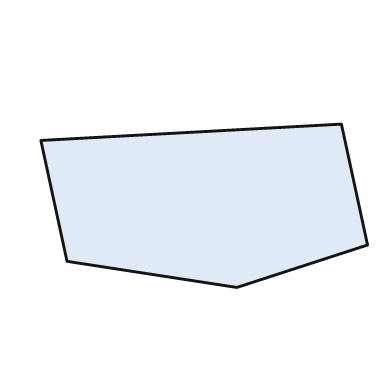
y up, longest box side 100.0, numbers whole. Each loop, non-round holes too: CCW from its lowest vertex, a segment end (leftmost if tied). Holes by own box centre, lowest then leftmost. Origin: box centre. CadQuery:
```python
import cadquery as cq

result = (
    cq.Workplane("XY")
    .moveTo(10.0, -25.0)
    .lineTo(50.0, -12.0)
    .lineTo(42.0, 25.0)
    .lineTo(-50.0, 20.0)
    .lineTo(-42.0, -17.0)
    .close()
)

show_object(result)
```